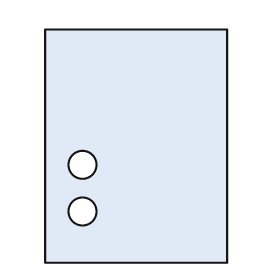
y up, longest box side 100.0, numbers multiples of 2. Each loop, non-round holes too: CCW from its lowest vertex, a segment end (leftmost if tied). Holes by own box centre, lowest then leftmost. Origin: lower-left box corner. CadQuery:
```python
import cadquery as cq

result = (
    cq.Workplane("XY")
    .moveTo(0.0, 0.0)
    .lineTo(78.0, 0.0)
    .lineTo(78.0, 100.0)
    .lineTo(0.0, 100.0)
    .close()
    .moveTo(16.0, 22.0)
    .circle(6.0)
    .moveTo(16.0, 42.0)
    .circle(6.0)
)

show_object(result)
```